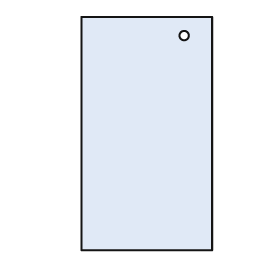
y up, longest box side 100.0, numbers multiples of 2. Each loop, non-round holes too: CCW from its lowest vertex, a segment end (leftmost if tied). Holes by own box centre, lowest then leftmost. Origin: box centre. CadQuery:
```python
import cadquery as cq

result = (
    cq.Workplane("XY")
    .moveTo(-28.0, -50.0)
    .lineTo(28.0, -50.0)
    .lineTo(28.0, 50.0)
    .lineTo(-28.0, 50.0)
    .close()
    .moveTo(16.0, 42.0)
    .circle(2.0)
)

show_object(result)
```